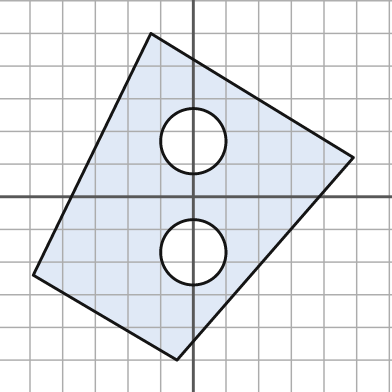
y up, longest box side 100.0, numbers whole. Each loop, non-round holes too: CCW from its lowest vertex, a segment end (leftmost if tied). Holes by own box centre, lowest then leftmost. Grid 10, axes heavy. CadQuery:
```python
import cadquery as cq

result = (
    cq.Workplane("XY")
    .moveTo(-5.0, -50.0)
    .lineTo(49.0, 12.0)
    .lineTo(-13.0, 50.0)
    .lineTo(-49.0, -24.0)
    .close()
    .moveTo(0.0, -17.0)
    .circle(10.0)
    .moveTo(0.0, 17.0)
    .circle(10.0)
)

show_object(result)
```